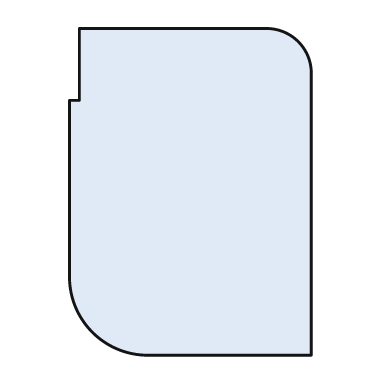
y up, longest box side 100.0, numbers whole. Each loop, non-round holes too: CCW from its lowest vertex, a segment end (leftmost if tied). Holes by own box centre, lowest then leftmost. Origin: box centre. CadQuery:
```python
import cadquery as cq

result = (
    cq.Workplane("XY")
    .moveTo(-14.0, -50.0)
    .lineTo(37.0, -50.0)
    .lineTo(37.0, 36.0)
    .threePointArc((33.0, 46.0), (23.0, 50.0))
    .lineTo(-34.0, 50.0)
    .lineTo(-34.0, 28.0)
    .lineTo(-37.0, 28.0)
    .lineTo(-37.0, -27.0)
    .threePointArc((-30.0, -43.0), (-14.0, -50.0))
    .close()
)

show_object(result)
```